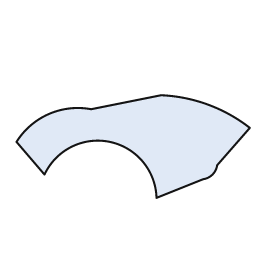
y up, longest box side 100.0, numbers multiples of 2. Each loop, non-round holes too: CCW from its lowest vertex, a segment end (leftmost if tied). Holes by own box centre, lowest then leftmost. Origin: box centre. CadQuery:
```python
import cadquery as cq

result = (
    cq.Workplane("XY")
    .moveTo(10.0, -22.0)
    .lineTo(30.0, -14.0)
    .threePointArc((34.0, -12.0), (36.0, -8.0))
    .lineTo(50.0, 8.0)
    .threePointArc((32.0, 18.0), (12.0, 22.0))
    .lineTo(-18.0, 16.0)
    .threePointArc((-36.0, 14.0), (-50.0, 2.0))
    .lineTo(-38.0, -12.0)
    .threePointArc((-10.0, 2.0), (10.0, -22.0))
    .close()
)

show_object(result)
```